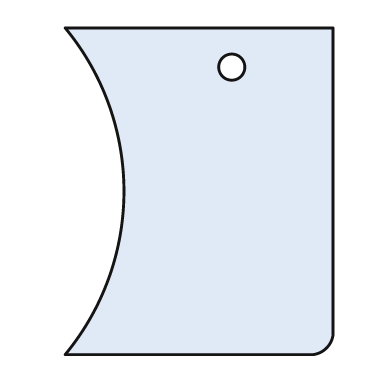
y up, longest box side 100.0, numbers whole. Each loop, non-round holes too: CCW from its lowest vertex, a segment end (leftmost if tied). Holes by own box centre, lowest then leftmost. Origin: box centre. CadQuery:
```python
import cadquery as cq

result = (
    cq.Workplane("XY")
    .moveTo(-41.0, -50.0)
    .lineTo(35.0, -50.0)
    .threePointArc((39.0, -48.0), (41.0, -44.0))
    .lineTo(41.0, 50.0)
    .lineTo(-41.0, 50.0)
    .threePointArc((-23.0, 0.0), (-41.0, -50.0))
    .close()
    .moveTo(10.0, 38.0)
    .circle(4.0)
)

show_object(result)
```